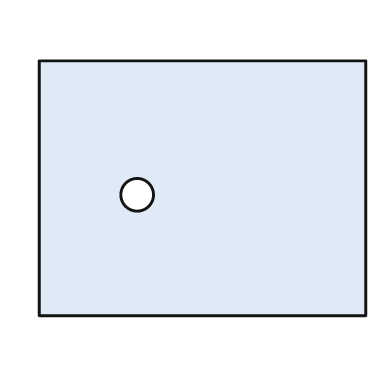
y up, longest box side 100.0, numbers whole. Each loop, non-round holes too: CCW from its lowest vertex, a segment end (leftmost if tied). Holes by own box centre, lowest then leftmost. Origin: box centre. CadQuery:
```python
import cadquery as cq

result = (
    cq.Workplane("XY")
    .moveTo(-50.0, -39.0)
    .lineTo(50.0, -39.0)
    .lineTo(50.0, 39.0)
    .lineTo(-50.0, 39.0)
    .close()
    .moveTo(-20.0, -2.0)
    .circle(5.0)
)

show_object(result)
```